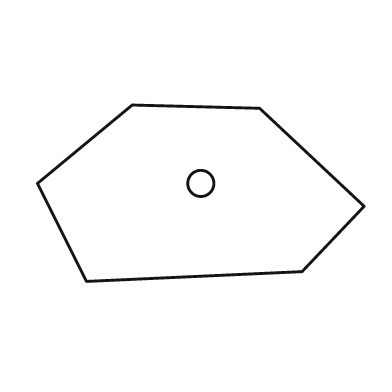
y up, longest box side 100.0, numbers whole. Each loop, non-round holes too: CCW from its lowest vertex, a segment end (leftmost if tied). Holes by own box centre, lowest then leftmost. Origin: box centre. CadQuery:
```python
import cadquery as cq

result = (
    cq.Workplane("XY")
    .moveTo(-35.0, -27.0)
    .lineTo(31.0, -24.0)
    .lineTo(50.0, -4.0)
    .lineTo(18.0, 26.0)
    .lineTo(-21.0, 27.0)
    .lineTo(-50.0, 3.0)
    .close()
    .moveTo(0.0, 3.0)
    .circle(4.0)
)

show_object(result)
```